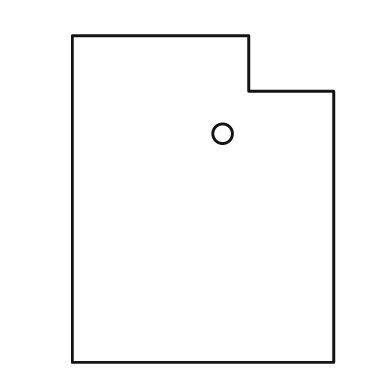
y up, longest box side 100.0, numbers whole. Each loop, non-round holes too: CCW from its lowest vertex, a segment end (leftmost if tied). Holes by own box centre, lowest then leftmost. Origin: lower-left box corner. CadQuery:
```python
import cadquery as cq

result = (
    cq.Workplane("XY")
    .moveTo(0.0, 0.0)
    .lineTo(80.0, 0.0)
    .lineTo(80.0, 83.0)
    .lineTo(54.0, 83.0)
    .lineTo(54.0, 100.0)
    .lineTo(0.0, 100.0)
    .close()
    .moveTo(46.0, 70.0)
    .circle(3.0)
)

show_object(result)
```